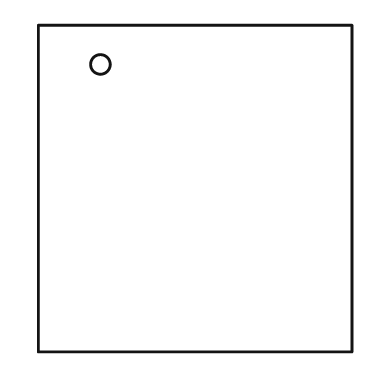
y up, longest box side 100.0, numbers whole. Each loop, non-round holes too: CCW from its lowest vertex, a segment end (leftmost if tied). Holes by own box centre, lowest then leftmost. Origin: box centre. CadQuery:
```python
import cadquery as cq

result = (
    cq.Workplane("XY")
    .moveTo(-48.0, -50.0)
    .lineTo(48.0, -50.0)
    .lineTo(48.0, 50.0)
    .lineTo(-48.0, 50.0)
    .close()
    .moveTo(-29.0, 38.0)
    .circle(3.0)
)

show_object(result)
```